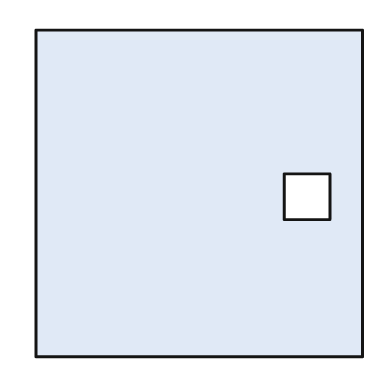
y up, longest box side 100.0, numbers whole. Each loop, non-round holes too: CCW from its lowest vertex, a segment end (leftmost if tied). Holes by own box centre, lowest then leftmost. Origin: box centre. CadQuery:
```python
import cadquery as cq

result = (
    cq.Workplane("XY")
    .moveTo(-50.0, -50.0)
    .lineTo(50.0, -50.0)
    .lineTo(50.0, 50.0)
    .lineTo(-50.0, 50.0)
    .close()
    .moveTo(26.0, -8.0)
    .lineTo(40.0, -8.0)
    .lineTo(40.0, 6.0)
    .lineTo(26.0, 6.0)
    .close()
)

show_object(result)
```